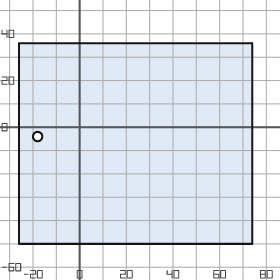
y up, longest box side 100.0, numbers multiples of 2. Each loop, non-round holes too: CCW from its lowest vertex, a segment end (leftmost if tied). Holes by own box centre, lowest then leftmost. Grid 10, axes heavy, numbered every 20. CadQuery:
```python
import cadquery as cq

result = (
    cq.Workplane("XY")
    .moveTo(-26.0, -50.0)
    .lineTo(74.0, -50.0)
    .lineTo(74.0, 36.0)
    .lineTo(-26.0, 36.0)
    .close()
    .moveTo(-18.0, -4.0)
    .circle(2.0)
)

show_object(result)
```